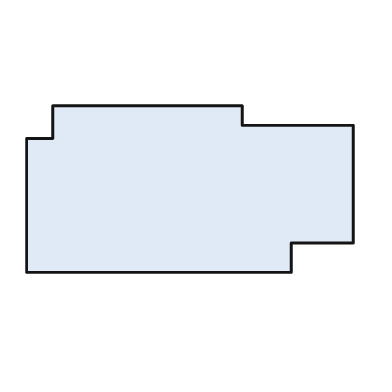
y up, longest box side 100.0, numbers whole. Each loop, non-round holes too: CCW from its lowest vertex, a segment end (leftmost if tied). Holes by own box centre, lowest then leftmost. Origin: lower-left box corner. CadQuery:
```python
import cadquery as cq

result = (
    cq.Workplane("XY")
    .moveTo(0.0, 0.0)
    .lineTo(81.0, 0.0)
    .lineTo(81.0, 9.0)
    .lineTo(100.0, 9.0)
    .lineTo(100.0, 45.0)
    .lineTo(66.0, 45.0)
    .lineTo(66.0, 51.0)
    .lineTo(8.0, 51.0)
    .lineTo(8.0, 41.0)
    .lineTo(0.0, 41.0)
    .close()
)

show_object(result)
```